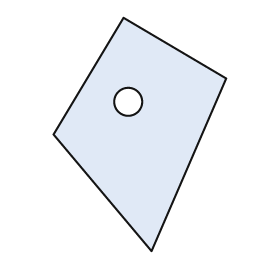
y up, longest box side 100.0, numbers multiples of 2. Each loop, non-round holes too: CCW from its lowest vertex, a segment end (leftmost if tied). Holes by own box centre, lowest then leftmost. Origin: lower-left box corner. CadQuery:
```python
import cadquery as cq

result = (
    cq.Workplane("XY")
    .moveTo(42.0, 0.0)
    .lineTo(74.0, 74.0)
    .lineTo(30.0, 100.0)
    .lineTo(0.0, 50.0)
    .close()
    .moveTo(32.0, 64.0)
    .circle(6.0)
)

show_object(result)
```